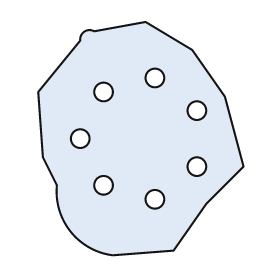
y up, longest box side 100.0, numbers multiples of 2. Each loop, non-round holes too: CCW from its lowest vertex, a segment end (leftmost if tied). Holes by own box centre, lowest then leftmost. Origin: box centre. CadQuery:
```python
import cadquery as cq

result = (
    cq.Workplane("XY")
    .moveTo(-12.0, -50.0)
    .lineTo(14.0, -48.0)
    .lineTo(28.0, -28.0)
    .lineTo(44.0, -12.0)
    .lineTo(36.0, 18.0)
    .lineTo(22.0, 38.0)
    .lineTo(2.0, 50.0)
    .lineTo(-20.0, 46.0)
    .threePointArc((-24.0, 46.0), (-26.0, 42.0))
    .lineTo(-44.0, 20.0)
    .lineTo(-42.0, -8.0)
    .lineTo(-36.0, -20.0)
    .threePointArc((-30.0, -40.0), (-12.0, -50.0))
    .close()
    .moveTo(6.0, -26.0)
    .circle(4.0)
    .moveTo(-16.0, -20.0)
    .circle(4.0)
    .moveTo(24.0, -12.0)
    .circle(4.0)
    .moveTo(-26.0, 0.0)
    .circle(4.0)
    .moveTo(24.0, 12.0)
    .circle(4.0)
    .moveTo(-16.0, 20.0)
    .circle(4.0)
    .moveTo(6.0, 26.0)
    .circle(4.0)
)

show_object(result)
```